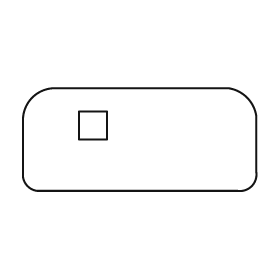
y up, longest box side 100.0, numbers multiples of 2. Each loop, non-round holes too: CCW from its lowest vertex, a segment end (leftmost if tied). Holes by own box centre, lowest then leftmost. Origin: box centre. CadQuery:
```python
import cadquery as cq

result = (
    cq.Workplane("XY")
    .moveTo(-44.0, -22.0)
    .lineTo(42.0, -22.0)
    .threePointArc((48.0, -20.0), (50.0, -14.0))
    .lineTo(50.0, 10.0)
    .threePointArc((46.0, 18.0), (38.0, 22.0))
    .lineTo(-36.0, 22.0)
    .threePointArc((-46.0, 18.0), (-50.0, 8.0))
    .lineTo(-50.0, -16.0)
    .threePointArc((-48.0, -20.0), (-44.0, -22.0))
    .close()
    .moveTo(-26.0, 0.0)
    .lineTo(-14.0, 0.0)
    .lineTo(-14.0, 12.0)
    .lineTo(-26.0, 12.0)
    .close()
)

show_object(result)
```